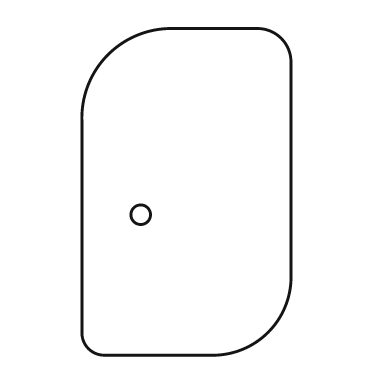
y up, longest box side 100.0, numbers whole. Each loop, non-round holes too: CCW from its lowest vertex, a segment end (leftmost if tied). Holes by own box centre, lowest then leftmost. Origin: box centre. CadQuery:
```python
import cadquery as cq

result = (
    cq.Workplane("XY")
    .moveTo(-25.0, -50.0)
    .lineTo(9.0, -50.0)
    .threePointArc((25.0, -43.0), (32.0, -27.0))
    .lineTo(32.0, 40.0)
    .threePointArc((29.0, 47.0), (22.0, 50.0))
    .lineTo(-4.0, 50.0)
    .threePointArc((-24.0, 42.0), (-32.0, 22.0))
    .lineTo(-32.0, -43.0)
    .threePointArc((-30.0, -48.0), (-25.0, -50.0))
    .close()
    .moveTo(-14.0, -7.0)
    .circle(3.0)
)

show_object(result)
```